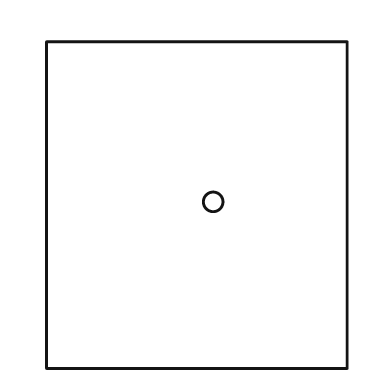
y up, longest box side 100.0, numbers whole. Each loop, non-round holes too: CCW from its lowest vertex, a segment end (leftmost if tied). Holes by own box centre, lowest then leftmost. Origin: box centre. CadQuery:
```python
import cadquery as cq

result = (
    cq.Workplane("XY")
    .moveTo(-46.0, -50.0)
    .lineTo(46.0, -50.0)
    .lineTo(46.0, 50.0)
    .lineTo(-46.0, 50.0)
    .close()
    .moveTo(5.0, 1.0)
    .circle(3.0)
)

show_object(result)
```